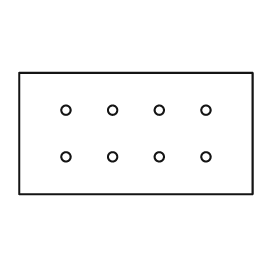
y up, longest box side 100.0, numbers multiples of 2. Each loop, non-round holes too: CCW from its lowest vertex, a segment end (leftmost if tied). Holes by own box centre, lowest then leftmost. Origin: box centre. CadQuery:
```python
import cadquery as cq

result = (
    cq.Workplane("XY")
    .moveTo(-50.0, -26.0)
    .lineTo(50.0, -26.0)
    .lineTo(50.0, 26.0)
    .lineTo(-50.0, 26.0)
    .close()
    .moveTo(-30.0, -10.0)
    .circle(2.0)
    .moveTo(-10.0, -10.0)
    .circle(2.0)
    .moveTo(10.0, -10.0)
    .circle(2.0)
    .moveTo(30.0, -10.0)
    .circle(2.0)
    .moveTo(-30.0, 10.0)
    .circle(2.0)
    .moveTo(-10.0, 10.0)
    .circle(2.0)
    .moveTo(10.0, 10.0)
    .circle(2.0)
    .moveTo(30.0, 10.0)
    .circle(2.0)
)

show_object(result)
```